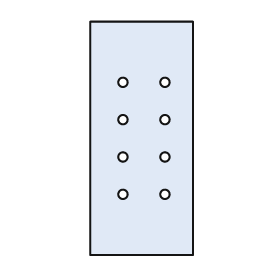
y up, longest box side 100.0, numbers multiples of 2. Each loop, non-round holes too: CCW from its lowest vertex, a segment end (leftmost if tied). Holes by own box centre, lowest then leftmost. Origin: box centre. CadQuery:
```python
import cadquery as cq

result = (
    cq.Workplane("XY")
    .moveTo(-22.0, -50.0)
    .lineTo(22.0, -50.0)
    .lineTo(22.0, 50.0)
    .lineTo(-22.0, 50.0)
    .close()
    .moveTo(-8.0, -24.0)
    .circle(2.0)
    .moveTo(10.0, -24.0)
    .circle(2.0)
    .moveTo(-8.0, -8.0)
    .circle(2.0)
    .moveTo(10.0, -8.0)
    .circle(2.0)
    .moveTo(-8.0, 8.0)
    .circle(2.0)
    .moveTo(10.0, 8.0)
    .circle(2.0)
    .moveTo(-8.0, 24.0)
    .circle(2.0)
    .moveTo(10.0, 24.0)
    .circle(2.0)
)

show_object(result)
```